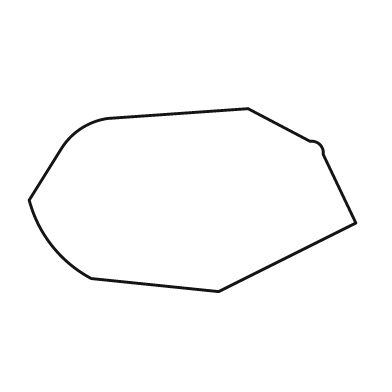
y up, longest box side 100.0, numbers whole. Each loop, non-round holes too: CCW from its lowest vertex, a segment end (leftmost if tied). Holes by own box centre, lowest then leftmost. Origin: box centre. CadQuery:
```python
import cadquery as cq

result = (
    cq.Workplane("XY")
    .moveTo(8.0, -28.0)
    .lineTo(50.0, -7.0)
    .lineTo(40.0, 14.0)
    .threePointArc((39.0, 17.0), (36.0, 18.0))
    .lineTo(17.0, 28.0)
    .lineTo(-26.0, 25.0)
    .threePointArc((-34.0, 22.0), (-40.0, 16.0))
    .lineTo(-50.0, 0.0)
    .threePointArc((-43.0, -14.0), (-31.0, -24.0))
    .close()
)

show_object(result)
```